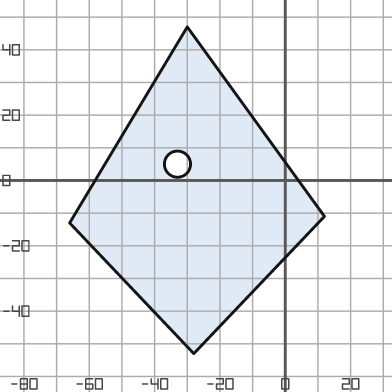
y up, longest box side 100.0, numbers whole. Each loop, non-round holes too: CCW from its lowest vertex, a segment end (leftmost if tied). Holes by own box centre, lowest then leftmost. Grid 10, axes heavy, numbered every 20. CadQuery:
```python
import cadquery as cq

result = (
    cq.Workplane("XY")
    .moveTo(-28.0, -53.0)
    .lineTo(12.0, -11.0)
    .lineTo(-30.0, 47.0)
    .lineTo(-66.0, -13.0)
    .close()
    .moveTo(-33.0, 5.0)
    .circle(4.0)
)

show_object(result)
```